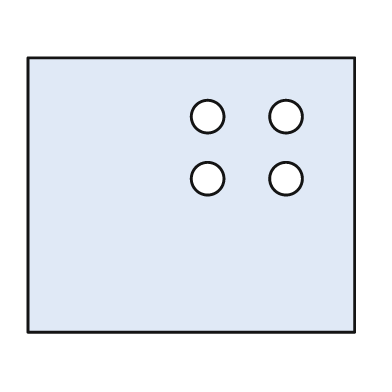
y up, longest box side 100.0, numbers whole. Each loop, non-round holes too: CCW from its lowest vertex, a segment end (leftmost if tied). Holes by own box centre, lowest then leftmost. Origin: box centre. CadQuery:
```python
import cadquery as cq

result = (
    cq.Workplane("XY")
    .moveTo(-50.0, -42.0)
    .lineTo(50.0, -42.0)
    .lineTo(50.0, 42.0)
    .lineTo(-50.0, 42.0)
    .close()
    .moveTo(5.0, 5.0)
    .circle(5.0)
    .moveTo(29.0, 5.0)
    .circle(5.0)
    .moveTo(5.0, 24.0)
    .circle(5.0)
    .moveTo(29.0, 24.0)
    .circle(5.0)
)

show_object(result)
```